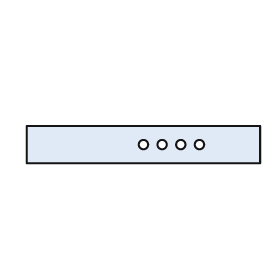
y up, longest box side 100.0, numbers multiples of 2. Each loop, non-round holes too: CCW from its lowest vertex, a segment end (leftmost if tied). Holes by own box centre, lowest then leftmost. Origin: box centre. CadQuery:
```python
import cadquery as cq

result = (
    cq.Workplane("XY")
    .moveTo(-50.0, -8.0)
    .lineTo(50.0, -8.0)
    .lineTo(50.0, 8.0)
    .lineTo(-50.0, 8.0)
    .close()
    .moveTo(0.0, 0.0)
    .circle(2.0)
    .moveTo(8.0, 0.0)
    .circle(2.0)
    .moveTo(16.0, 0.0)
    .circle(2.0)
    .moveTo(24.0, 0.0)
    .circle(2.0)
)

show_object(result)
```